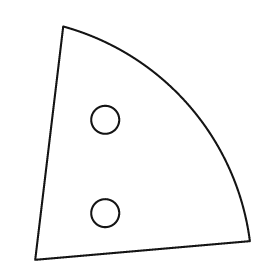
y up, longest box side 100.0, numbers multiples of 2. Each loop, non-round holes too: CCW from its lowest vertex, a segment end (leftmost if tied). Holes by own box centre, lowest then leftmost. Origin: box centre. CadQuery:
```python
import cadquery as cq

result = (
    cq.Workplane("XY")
    .moveTo(-46.0, -50.0)
    .lineTo(46.0, -42.0)
    .threePointArc((20.0, 16.0), (-34.0, 50.0))
    .close()
    .moveTo(-16.0, -30.0)
    .circle(6.0)
    .moveTo(-16.0, 10.0)
    .circle(6.0)
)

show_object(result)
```